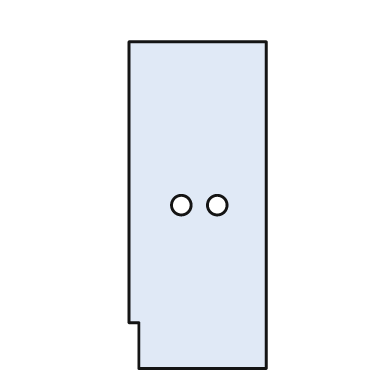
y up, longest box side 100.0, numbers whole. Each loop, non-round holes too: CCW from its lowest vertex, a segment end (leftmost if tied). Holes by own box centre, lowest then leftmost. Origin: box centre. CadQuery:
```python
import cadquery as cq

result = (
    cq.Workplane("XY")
    .moveTo(-18.0, -50.0)
    .lineTo(21.0, -50.0)
    .lineTo(21.0, 50.0)
    .lineTo(-21.0, 50.0)
    .lineTo(-21.0, -36.0)
    .lineTo(-18.0, -36.0)
    .close()
    .moveTo(-5.0, 0.0)
    .circle(3.0)
    .moveTo(6.0, 0.0)
    .circle(3.0)
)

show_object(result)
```